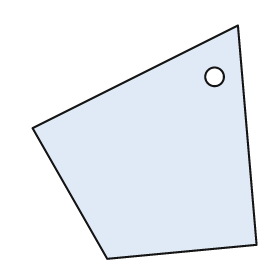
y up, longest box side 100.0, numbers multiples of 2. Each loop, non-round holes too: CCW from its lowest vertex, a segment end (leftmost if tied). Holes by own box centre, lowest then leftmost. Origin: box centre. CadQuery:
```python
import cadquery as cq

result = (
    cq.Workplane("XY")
    .moveTo(-16.0, -50.0)
    .lineTo(48.0, -44.0)
    .lineTo(40.0, 50.0)
    .lineTo(-48.0, 6.0)
    .close()
    .moveTo(30.0, 28.0)
    .circle(4.0)
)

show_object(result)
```